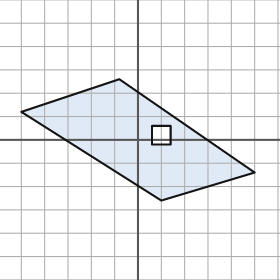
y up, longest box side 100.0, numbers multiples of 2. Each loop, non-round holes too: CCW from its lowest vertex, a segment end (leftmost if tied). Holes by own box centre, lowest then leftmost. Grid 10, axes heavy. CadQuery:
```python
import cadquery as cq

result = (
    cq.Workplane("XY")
    .moveTo(10.0, -26.0)
    .lineTo(50.0, -14.0)
    .lineTo(-8.0, 26.0)
    .lineTo(-50.0, 12.0)
    .close()
    .moveTo(6.0, -2.0)
    .lineTo(14.0, -2.0)
    .lineTo(14.0, 6.0)
    .lineTo(6.0, 6.0)
    .close()
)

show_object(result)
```